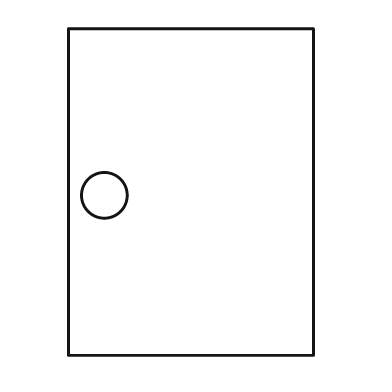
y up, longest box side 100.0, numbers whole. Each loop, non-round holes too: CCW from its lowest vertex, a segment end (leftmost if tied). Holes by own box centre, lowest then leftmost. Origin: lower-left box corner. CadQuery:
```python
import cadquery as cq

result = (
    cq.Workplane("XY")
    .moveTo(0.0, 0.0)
    .lineTo(75.0, 0.0)
    .lineTo(75.0, 100.0)
    .lineTo(0.0, 100.0)
    .close()
    .moveTo(11.0, 49.0)
    .circle(7.0)
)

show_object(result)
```